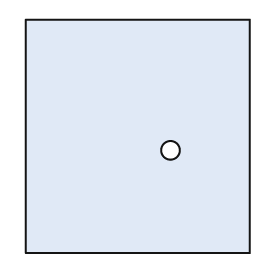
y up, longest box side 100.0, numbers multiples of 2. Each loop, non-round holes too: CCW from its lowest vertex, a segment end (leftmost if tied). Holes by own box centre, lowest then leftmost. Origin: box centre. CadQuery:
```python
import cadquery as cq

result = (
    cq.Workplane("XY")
    .moveTo(-48.0, -50.0)
    .lineTo(48.0, -50.0)
    .lineTo(48.0, 50.0)
    .lineTo(-48.0, 50.0)
    .close()
    .moveTo(14.0, -6.0)
    .circle(4.0)
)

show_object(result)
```